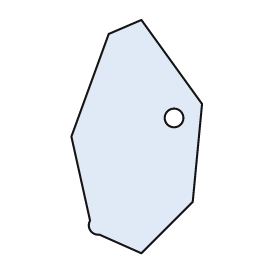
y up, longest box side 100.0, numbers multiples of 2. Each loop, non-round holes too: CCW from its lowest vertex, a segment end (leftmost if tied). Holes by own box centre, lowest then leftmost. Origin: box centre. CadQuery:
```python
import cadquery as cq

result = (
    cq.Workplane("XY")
    .moveTo(2.0, -50.0)
    .lineTo(24.0, -28.0)
    .lineTo(28.0, 14.0)
    .lineTo(2.0, 50.0)
    .lineTo(-12.0, 44.0)
    .lineTo(-28.0, 0.0)
    .lineTo(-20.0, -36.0)
    .threePointArc((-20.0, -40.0), (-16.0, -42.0))
    .close()
    .moveTo(16.0, 8.0)
    .circle(4.0)
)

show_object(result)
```